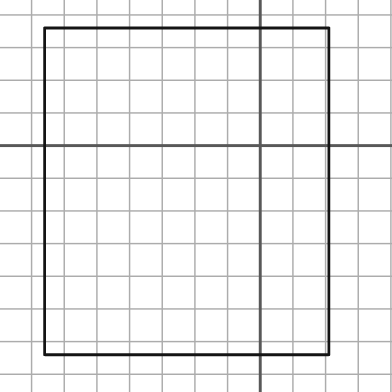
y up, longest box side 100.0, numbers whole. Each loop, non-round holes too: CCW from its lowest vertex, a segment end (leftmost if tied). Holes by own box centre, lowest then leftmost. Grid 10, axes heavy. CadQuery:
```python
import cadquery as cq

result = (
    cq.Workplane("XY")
    .moveTo(-66.0, -64.0)
    .lineTo(21.0, -64.0)
    .lineTo(21.0, 36.0)
    .lineTo(-66.0, 36.0)
    .close()
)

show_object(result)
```